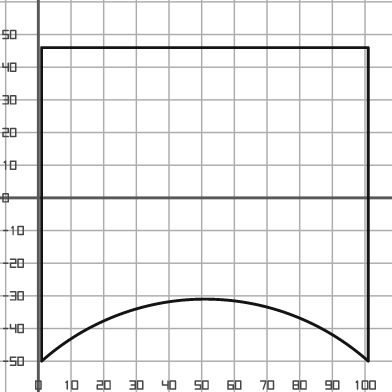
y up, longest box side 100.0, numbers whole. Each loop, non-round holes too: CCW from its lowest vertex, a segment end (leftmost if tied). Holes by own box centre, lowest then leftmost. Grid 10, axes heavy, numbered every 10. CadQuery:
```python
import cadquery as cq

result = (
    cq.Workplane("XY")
    .moveTo(1.0, -50.0)
    .threePointArc((51.0, -31.0), (101.0, -50.0))
    .lineTo(101.0, 46.0)
    .lineTo(1.0, 46.0)
    .close()
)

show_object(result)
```